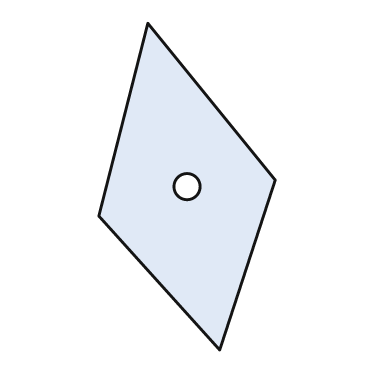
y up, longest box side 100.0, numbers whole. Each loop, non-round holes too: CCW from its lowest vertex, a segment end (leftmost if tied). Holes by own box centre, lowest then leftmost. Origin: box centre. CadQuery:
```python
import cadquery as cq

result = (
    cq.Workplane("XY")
    .moveTo(10.0, -50.0)
    .lineTo(27.0, 2.0)
    .lineTo(-12.0, 50.0)
    .lineTo(-27.0, -9.0)
    .close()
    .moveTo(0.0, 0.0)
    .circle(4.0)
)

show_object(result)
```